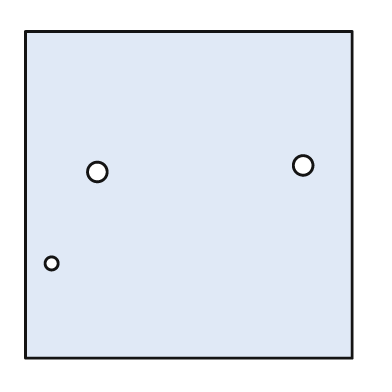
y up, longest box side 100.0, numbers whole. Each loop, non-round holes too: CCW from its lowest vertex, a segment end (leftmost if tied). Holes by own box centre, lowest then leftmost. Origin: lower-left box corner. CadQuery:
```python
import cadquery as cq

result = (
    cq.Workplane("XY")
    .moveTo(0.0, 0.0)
    .lineTo(100.0, 0.0)
    .lineTo(100.0, 100.0)
    .lineTo(0.0, 100.0)
    .close()
    .moveTo(8.0, 29.0)
    .circle(2.0)
    .moveTo(22.0, 57.0)
    .circle(3.0)
    .moveTo(85.0, 59.0)
    .circle(3.0)
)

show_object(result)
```